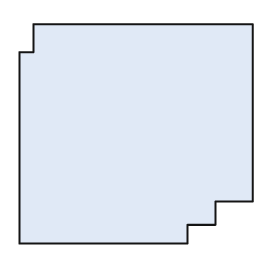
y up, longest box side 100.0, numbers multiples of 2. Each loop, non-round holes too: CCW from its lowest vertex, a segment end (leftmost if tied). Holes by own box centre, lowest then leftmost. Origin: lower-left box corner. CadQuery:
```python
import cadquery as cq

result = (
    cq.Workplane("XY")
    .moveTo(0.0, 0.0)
    .lineTo(72.0, 0.0)
    .lineTo(72.0, 8.0)
    .lineTo(84.0, 8.0)
    .lineTo(84.0, 18.0)
    .lineTo(100.0, 18.0)
    .lineTo(100.0, 94.0)
    .lineTo(6.0, 94.0)
    .lineTo(6.0, 82.0)
    .lineTo(0.0, 82.0)
    .close()
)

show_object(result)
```